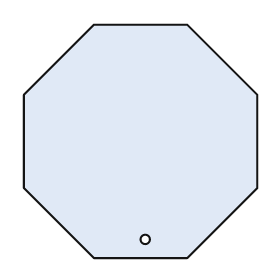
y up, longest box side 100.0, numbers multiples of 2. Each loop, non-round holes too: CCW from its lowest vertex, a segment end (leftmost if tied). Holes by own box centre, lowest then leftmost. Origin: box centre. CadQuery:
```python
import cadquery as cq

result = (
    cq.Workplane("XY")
    .moveTo(-20.0, -50.0)
    .lineTo(20.0, -50.0)
    .lineTo(50.0, -20.0)
    .lineTo(50.0, 20.0)
    .lineTo(20.0, 50.0)
    .lineTo(-20.0, 50.0)
    .lineTo(-50.0, 20.0)
    .lineTo(-50.0, -20.0)
    .close()
    .moveTo(2.0, -42.0)
    .circle(2.0)
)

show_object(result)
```